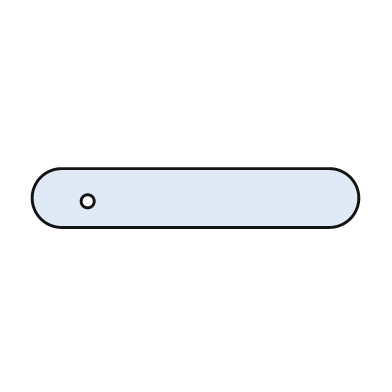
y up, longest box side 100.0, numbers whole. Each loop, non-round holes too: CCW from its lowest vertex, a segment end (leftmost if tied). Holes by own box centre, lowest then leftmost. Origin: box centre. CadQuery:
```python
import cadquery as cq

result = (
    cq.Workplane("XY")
    .moveTo(-41.0, -9.0)
    .lineTo(41.0, -9.0)
    .threePointArc((50.0, 0.0), (41.0, 9.0))
    .lineTo(-41.0, 9.0)
    .threePointArc((-50.0, 0.0), (-41.0, -9.0))
    .close()
    .moveTo(-33.0, -1.0)
    .circle(2.0)
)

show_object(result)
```